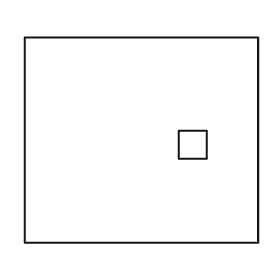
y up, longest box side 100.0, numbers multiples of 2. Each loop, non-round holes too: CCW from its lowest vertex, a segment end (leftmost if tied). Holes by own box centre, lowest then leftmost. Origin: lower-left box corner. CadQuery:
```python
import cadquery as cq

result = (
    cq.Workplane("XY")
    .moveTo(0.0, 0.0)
    .lineTo(100.0, 0.0)
    .lineTo(100.0, 88.0)
    .lineTo(0.0, 88.0)
    .close()
    .moveTo(66.0, 36.0)
    .lineTo(78.0, 36.0)
    .lineTo(78.0, 48.0)
    .lineTo(66.0, 48.0)
    .close()
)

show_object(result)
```